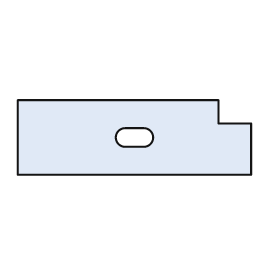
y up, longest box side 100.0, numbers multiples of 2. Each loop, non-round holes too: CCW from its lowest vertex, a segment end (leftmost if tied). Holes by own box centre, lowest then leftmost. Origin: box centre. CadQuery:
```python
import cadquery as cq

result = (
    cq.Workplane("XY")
    .moveTo(-50.0, -16.0)
    .lineTo(50.0, -16.0)
    .lineTo(50.0, 6.0)
    .lineTo(36.0, 6.0)
    .lineTo(36.0, 16.0)
    .lineTo(-50.0, 16.0)
    .close()
    .moveTo(-4.0, -4.0)
    .lineTo(4.0, -4.0)
    .threePointArc((8.0, 0.0), (4.0, 4.0))
    .lineTo(-4.0, 4.0)
    .threePointArc((-8.0, 0.0), (-4.0, -4.0))
    .close()
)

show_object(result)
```